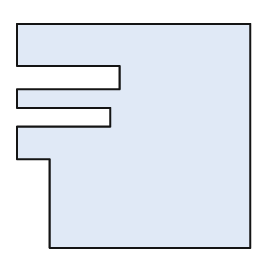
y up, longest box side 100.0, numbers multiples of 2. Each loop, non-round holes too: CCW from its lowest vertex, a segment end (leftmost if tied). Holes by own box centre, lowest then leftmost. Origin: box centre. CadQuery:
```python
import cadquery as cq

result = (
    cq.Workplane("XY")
    .moveTo(-36.0, -48.0)
    .lineTo(50.0, -48.0)
    .lineTo(50.0, 48.0)
    .lineTo(-50.0, 48.0)
    .lineTo(-50.0, 30.0)
    .lineTo(-6.0, 30.0)
    .lineTo(-6.0, 20.0)
    .lineTo(-50.0, 20.0)
    .lineTo(-50.0, 12.0)
    .lineTo(-10.0, 12.0)
    .lineTo(-10.0, 4.0)
    .lineTo(-50.0, 4.0)
    .lineTo(-50.0, -10.0)
    .lineTo(-36.0, -10.0)
    .close()
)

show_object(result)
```